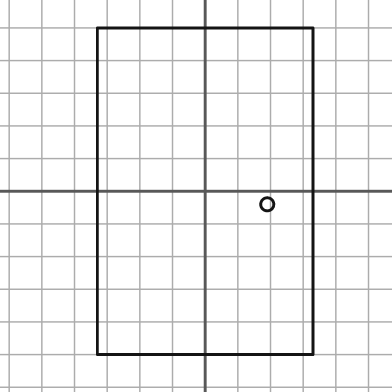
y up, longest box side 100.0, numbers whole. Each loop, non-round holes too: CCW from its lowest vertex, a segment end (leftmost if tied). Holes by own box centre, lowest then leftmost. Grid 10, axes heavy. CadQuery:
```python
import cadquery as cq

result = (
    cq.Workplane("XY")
    .moveTo(-33.0, -50.0)
    .lineTo(33.0, -50.0)
    .lineTo(33.0, 50.0)
    .lineTo(-33.0, 50.0)
    .close()
    .moveTo(19.0, -4.0)
    .circle(2.0)
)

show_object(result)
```